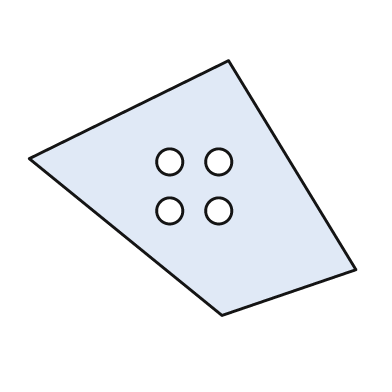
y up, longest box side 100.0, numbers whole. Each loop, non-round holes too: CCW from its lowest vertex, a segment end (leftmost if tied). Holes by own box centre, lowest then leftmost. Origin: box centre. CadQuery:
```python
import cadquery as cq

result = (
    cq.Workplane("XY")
    .moveTo(9.0, -39.0)
    .lineTo(50.0, -25.0)
    .lineTo(11.0, 39.0)
    .lineTo(-50.0, 9.0)
    .close()
    .moveTo(-7.0, -7.0)
    .circle(4.0)
    .moveTo(8.0, -7.0)
    .circle(4.0)
    .moveTo(-7.0, 8.0)
    .circle(4.0)
    .moveTo(8.0, 8.0)
    .circle(4.0)
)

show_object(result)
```